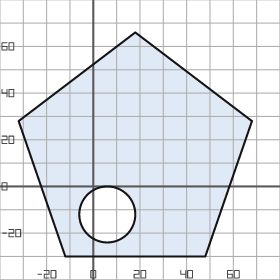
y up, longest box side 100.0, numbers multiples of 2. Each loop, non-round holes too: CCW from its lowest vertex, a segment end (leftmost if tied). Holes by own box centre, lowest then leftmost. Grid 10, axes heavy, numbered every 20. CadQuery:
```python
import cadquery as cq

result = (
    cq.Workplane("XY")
    .moveTo(-12.0, -30.0)
    .lineTo(48.0, -30.0)
    .lineTo(68.0, 28.0)
    .lineTo(18.0, 66.0)
    .lineTo(-32.0, 28.0)
    .close()
    .moveTo(6.0, -12.0)
    .circle(12.0)
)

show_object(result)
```